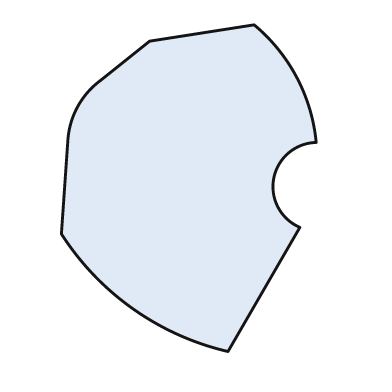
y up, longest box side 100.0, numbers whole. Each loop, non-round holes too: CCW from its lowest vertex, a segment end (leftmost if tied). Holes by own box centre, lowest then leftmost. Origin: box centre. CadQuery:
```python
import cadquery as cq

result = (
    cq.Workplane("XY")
    .moveTo(12.0, -50.0)
    .lineTo(34.0, -12.0)
    .threePointArc((26.0, 3.0), (39.0, 14.0))
    .threePointArc((33.0, 34.0), (20.0, 50.0))
    .lineTo(-12.0, 45.0)
    .lineTo(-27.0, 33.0)
    .threePointArc((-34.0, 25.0), (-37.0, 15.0))
    .lineTo(-39.0, -14.0)
    .threePointArc((-17.0, -37.0), (12.0, -50.0))
    .close()
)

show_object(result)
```